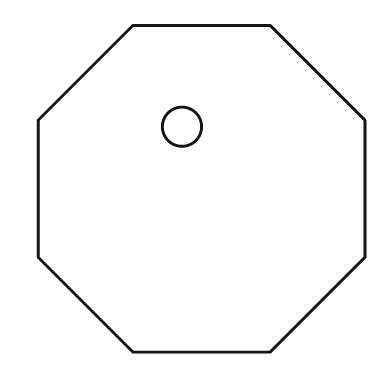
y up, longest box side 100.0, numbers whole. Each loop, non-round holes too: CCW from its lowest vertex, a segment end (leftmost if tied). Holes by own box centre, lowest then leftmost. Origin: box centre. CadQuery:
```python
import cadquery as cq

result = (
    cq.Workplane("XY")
    .moveTo(-21.0, -50.0)
    .lineTo(21.0, -50.0)
    .lineTo(50.0, -21.0)
    .lineTo(50.0, 21.0)
    .lineTo(21.0, 50.0)
    .lineTo(-21.0, 50.0)
    .lineTo(-50.0, 21.0)
    .lineTo(-50.0, -21.0)
    .close()
    .moveTo(-6.0, 19.0)
    .circle(6.0)
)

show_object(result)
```